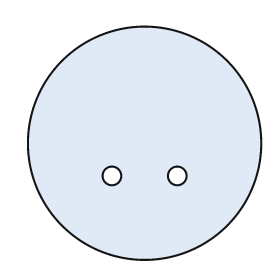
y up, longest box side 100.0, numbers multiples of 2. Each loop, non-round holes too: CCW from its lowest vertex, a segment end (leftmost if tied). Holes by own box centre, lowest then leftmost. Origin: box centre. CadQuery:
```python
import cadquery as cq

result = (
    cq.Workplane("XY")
    .moveTo(0.0, 0.0)
    .circle(50.0)
    .moveTo(-14.0, -14.0)
    .circle(4.0)
    .moveTo(14.0, -14.0)
    .circle(4.0)
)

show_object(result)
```